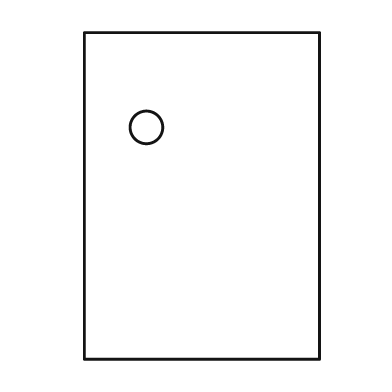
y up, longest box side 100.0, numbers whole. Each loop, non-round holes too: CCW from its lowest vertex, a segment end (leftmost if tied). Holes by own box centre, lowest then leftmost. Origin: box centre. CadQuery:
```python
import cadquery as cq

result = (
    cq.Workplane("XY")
    .moveTo(-36.0, -50.0)
    .lineTo(36.0, -50.0)
    .lineTo(36.0, 50.0)
    .lineTo(-36.0, 50.0)
    .close()
    .moveTo(-17.0, 21.0)
    .circle(5.0)
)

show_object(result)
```